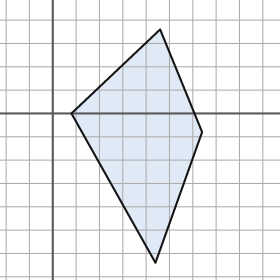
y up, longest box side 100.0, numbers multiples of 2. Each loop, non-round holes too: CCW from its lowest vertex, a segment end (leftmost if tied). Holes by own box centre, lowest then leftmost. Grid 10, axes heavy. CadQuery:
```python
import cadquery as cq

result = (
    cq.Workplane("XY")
    .moveTo(44.0, -64.0)
    .lineTo(64.0, -8.0)
    .lineTo(46.0, 36.0)
    .lineTo(8.0, 0.0)
    .close()
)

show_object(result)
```